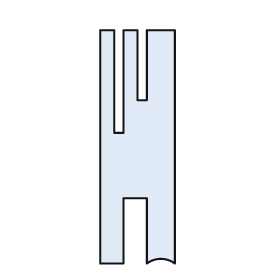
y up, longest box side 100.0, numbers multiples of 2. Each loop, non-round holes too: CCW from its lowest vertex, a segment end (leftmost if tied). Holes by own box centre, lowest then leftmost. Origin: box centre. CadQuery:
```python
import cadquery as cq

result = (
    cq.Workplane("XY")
    .moveTo(-16.0, -50.0)
    .lineTo(-6.0, -50.0)
    .lineTo(-6.0, -22.0)
    .lineTo(4.0, -22.0)
    .lineTo(4.0, -50.0)
    .threePointArc((10.0, -48.0), (16.0, -50.0))
    .lineTo(16.0, 50.0)
    .lineTo(4.0, 50.0)
    .lineTo(4.0, 20.0)
    .lineTo(0.0, 20.0)
    .lineTo(0.0, 50.0)
    .lineTo(-6.0, 50.0)
    .lineTo(-6.0, 6.0)
    .lineTo(-10.0, 6.0)
    .lineTo(-10.0, 50.0)
    .lineTo(-16.0, 50.0)
    .close()
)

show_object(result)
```